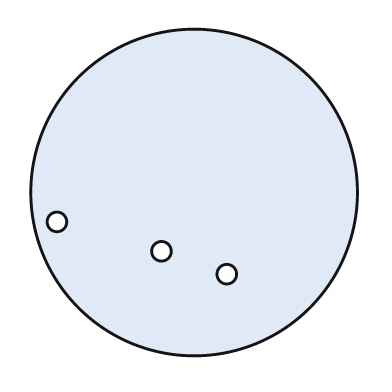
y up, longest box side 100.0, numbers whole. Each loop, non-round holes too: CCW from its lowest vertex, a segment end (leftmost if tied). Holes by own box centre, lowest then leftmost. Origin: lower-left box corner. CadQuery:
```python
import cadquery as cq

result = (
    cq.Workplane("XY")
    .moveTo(50.0, 50.0)
    .circle(50.0)
    .moveTo(60.0, 25.0)
    .circle(3.0)
    .moveTo(40.0, 32.0)
    .circle(3.0)
    .moveTo(8.0, 41.0)
    .circle(3.0)
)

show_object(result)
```